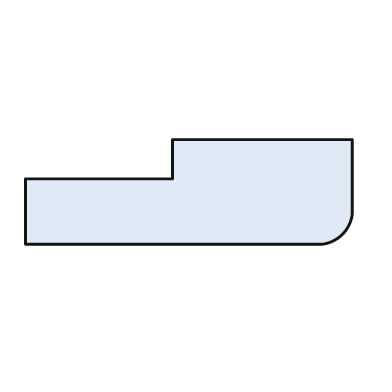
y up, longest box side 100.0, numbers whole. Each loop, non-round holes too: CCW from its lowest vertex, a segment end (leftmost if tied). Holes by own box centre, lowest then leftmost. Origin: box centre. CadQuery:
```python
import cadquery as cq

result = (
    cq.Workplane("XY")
    .moveTo(-50.0, -16.0)
    .lineTo(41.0, -16.0)
    .threePointArc((47.0, -13.0), (50.0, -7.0))
    .lineTo(50.0, 16.0)
    .lineTo(-5.0, 16.0)
    .lineTo(-5.0, 4.0)
    .lineTo(-50.0, 4.0)
    .close()
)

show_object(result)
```